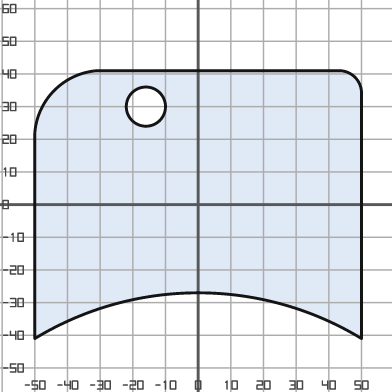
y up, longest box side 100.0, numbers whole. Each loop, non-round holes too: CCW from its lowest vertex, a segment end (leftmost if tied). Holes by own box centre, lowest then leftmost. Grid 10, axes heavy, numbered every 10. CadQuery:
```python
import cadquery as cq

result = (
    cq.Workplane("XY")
    .moveTo(-50.0, -41.0)
    .threePointArc((0.0, -27.0), (50.0, -41.0))
    .lineTo(50.0, 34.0)
    .threePointArc((48.0, 39.0), (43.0, 41.0))
    .lineTo(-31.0, 41.0)
    .threePointArc((-44.0, 35.0), (-50.0, 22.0))
    .close()
    .moveTo(-16.0, 30.0)
    .circle(6.0)
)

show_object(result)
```